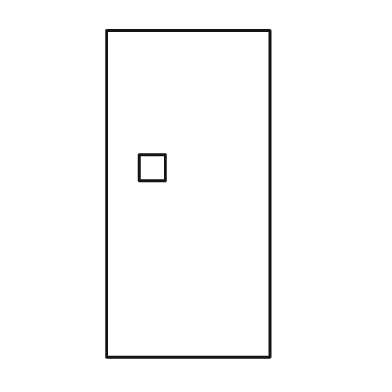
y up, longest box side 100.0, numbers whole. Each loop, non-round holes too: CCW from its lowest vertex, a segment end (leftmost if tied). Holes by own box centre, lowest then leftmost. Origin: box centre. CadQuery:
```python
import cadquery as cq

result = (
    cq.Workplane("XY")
    .moveTo(-25.0, -50.0)
    .lineTo(25.0, -50.0)
    .lineTo(25.0, 50.0)
    .lineTo(-25.0, 50.0)
    .close()
    .moveTo(-15.0, 4.0)
    .lineTo(-7.0, 4.0)
    .lineTo(-7.0, 12.0)
    .lineTo(-15.0, 12.0)
    .close()
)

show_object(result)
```